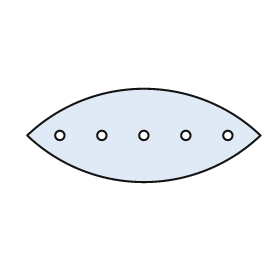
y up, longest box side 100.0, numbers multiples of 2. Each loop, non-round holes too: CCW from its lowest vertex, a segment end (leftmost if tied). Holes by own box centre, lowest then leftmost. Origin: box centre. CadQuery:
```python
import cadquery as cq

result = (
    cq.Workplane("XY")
    .moveTo(-50.0, 0.0)
    .threePointArc((0.0, -20.0), (50.0, 0.0))
    .threePointArc((0.0, 20.0), (-50.0, 0.0))
    .close()
    .moveTo(-36.0, 0.0)
    .circle(2.0)
    .moveTo(-18.0, 0.0)
    .circle(2.0)
    .moveTo(0.0, 0.0)
    .circle(2.0)
    .moveTo(18.0, 0.0)
    .circle(2.0)
    .moveTo(36.0, 0.0)
    .circle(2.0)
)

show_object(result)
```